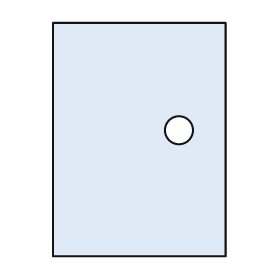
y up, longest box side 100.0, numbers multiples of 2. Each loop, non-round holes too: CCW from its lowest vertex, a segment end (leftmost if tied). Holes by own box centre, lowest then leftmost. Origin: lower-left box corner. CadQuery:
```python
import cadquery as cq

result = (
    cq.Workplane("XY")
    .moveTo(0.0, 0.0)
    .lineTo(74.0, 0.0)
    .lineTo(74.0, 100.0)
    .lineTo(0.0, 100.0)
    .close()
    .moveTo(54.0, 54.0)
    .circle(6.0)
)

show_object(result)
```